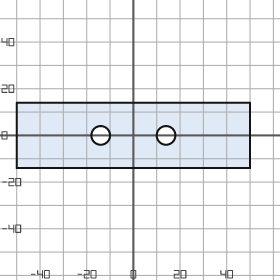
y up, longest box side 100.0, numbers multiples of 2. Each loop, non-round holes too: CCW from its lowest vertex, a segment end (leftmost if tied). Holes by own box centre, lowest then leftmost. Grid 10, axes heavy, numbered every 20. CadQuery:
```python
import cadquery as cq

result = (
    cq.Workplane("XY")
    .moveTo(-50.0, -14.0)
    .lineTo(50.0, -14.0)
    .lineTo(50.0, 14.0)
    .lineTo(-50.0, 14.0)
    .close()
    .moveTo(-14.0, 0.0)
    .circle(4.0)
    .moveTo(14.0, 0.0)
    .circle(4.0)
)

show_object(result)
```